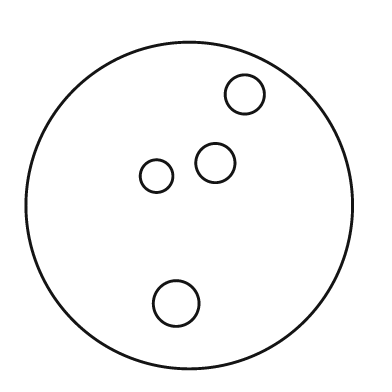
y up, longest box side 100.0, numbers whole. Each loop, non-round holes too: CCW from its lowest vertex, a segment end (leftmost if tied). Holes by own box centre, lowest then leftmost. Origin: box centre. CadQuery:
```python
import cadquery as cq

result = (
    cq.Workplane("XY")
    .moveTo(0.0, 0.0)
    .circle(50.0)
    .moveTo(-4.0, -30.0)
    .circle(7.0)
    .moveTo(-10.0, 9.0)
    .circle(5.0)
    .moveTo(8.0, 13.0)
    .circle(6.0)
    .moveTo(17.0, 34.0)
    .circle(6.0)
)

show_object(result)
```